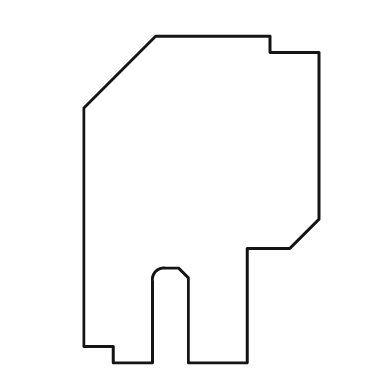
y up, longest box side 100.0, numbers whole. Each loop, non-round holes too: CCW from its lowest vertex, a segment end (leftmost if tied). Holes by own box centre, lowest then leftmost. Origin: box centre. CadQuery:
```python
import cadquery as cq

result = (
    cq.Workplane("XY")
    .moveTo(-27.0, -50.0)
    .lineTo(-15.0, -50.0)
    .lineTo(-15.0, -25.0)
    .threePointArc((-14.0, -22.0), (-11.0, -21.0))
    .lineTo(-7.0, -21.0)
    .lineTo(-4.0, -24.0)
    .lineTo(-4.0, -50.0)
    .lineTo(14.0, -50.0)
    .lineTo(14.0, -15.0)
    .lineTo(27.0, -15.0)
    .lineTo(36.0, -6.0)
    .lineTo(36.0, 45.0)
    .lineTo(21.0, 45.0)
    .lineTo(21.0, 50.0)
    .lineTo(-14.0, 50.0)
    .lineTo(-36.0, 28.0)
    .lineTo(-36.0, -45.0)
    .lineTo(-27.0, -45.0)
    .close()
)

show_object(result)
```